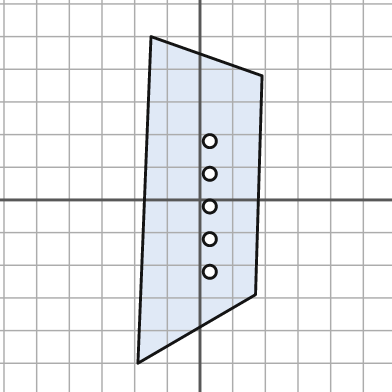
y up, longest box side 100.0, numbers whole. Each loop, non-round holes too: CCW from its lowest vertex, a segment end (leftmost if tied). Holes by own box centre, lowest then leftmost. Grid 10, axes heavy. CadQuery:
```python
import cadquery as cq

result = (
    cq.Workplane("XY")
    .moveTo(-19.0, -50.0)
    .lineTo(17.0, -29.0)
    .lineTo(19.0, 38.0)
    .lineTo(-15.0, 50.0)
    .close()
    .moveTo(3.0, -22.0)
    .circle(2.0)
    .moveTo(3.0, -12.0)
    .circle(2.0)
    .moveTo(3.0, -2.0)
    .circle(2.0)
    .moveTo(3.0, 8.0)
    .circle(2.0)
    .moveTo(3.0, 18.0)
    .circle(2.0)
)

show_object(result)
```